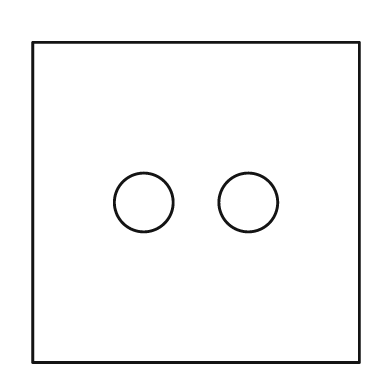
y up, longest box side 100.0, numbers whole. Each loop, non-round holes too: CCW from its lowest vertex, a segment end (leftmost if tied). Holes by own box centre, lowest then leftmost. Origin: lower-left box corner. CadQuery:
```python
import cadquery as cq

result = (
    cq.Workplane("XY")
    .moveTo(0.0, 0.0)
    .lineTo(100.0, 0.0)
    .lineTo(100.0, 98.0)
    .lineTo(0.0, 98.0)
    .close()
    .moveTo(34.0, 49.0)
    .circle(9.0)
    .moveTo(66.0, 49.0)
    .circle(9.0)
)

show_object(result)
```